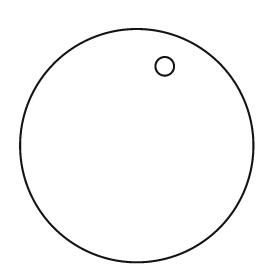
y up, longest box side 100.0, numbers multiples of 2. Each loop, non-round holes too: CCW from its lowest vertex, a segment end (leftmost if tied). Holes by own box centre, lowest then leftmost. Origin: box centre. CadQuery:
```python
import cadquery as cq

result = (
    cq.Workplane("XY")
    .moveTo(0.0, 0.0)
    .circle(50.0)
    .moveTo(12.0, 34.0)
    .circle(4.0)
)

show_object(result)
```